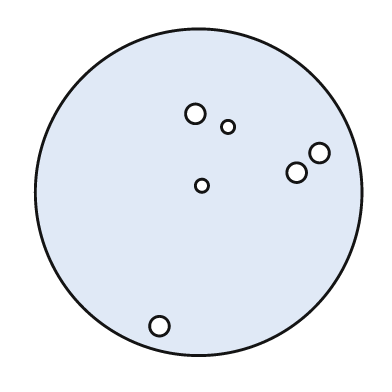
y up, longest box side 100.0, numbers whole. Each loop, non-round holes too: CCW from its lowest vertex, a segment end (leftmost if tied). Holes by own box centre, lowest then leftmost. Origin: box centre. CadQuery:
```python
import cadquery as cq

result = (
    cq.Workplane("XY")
    .moveTo(0.0, 0.0)
    .circle(50.0)
    .moveTo(-12.0, -41.0)
    .circle(3.0)
    .moveTo(1.0, 2.0)
    .circle(2.0)
    .moveTo(30.0, 6.0)
    .circle(3.0)
    .moveTo(37.0, 12.0)
    .circle(3.0)
    .moveTo(9.0, 20.0)
    .circle(2.0)
    .moveTo(-1.0, 24.0)
    .circle(3.0)
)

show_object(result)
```